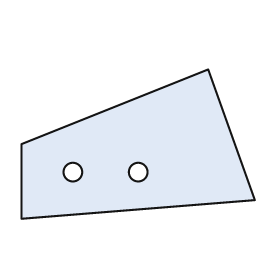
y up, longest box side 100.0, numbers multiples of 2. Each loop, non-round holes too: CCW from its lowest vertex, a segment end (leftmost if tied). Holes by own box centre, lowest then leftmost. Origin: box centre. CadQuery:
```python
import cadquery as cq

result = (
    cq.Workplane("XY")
    .moveTo(-50.0, -32.0)
    .lineTo(50.0, -24.0)
    .lineTo(30.0, 32.0)
    .lineTo(-50.0, 0.0)
    .close()
    .moveTo(-28.0, -12.0)
    .circle(4.0)
    .moveTo(0.0, -12.0)
    .circle(4.0)
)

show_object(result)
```